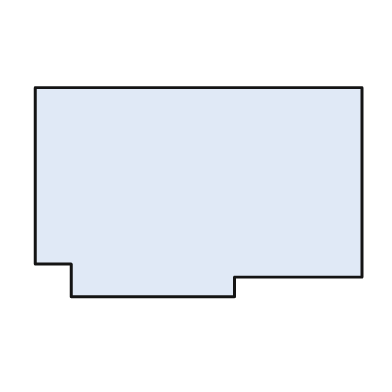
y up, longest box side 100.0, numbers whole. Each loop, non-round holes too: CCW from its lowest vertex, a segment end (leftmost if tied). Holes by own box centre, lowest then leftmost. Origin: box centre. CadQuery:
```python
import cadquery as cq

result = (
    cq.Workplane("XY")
    .moveTo(-39.0, -32.0)
    .lineTo(11.0, -32.0)
    .lineTo(11.0, -26.0)
    .lineTo(50.0, -26.0)
    .lineTo(50.0, 32.0)
    .lineTo(-50.0, 32.0)
    .lineTo(-50.0, -22.0)
    .lineTo(-39.0, -22.0)
    .close()
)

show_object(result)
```